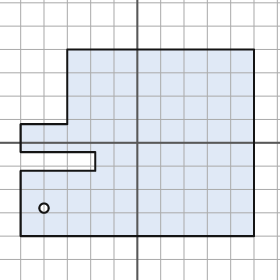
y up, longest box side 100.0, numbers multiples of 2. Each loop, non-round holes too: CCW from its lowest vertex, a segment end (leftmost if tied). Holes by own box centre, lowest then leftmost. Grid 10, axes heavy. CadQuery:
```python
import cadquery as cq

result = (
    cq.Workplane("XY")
    .moveTo(-50.0, -40.0)
    .lineTo(50.0, -40.0)
    .lineTo(50.0, 40.0)
    .lineTo(-30.0, 40.0)
    .lineTo(-30.0, 8.0)
    .lineTo(-50.0, 8.0)
    .lineTo(-50.0, -4.0)
    .lineTo(-18.0, -4.0)
    .lineTo(-18.0, -12.0)
    .lineTo(-50.0, -12.0)
    .close()
    .moveTo(-40.0, -28.0)
    .circle(2.0)
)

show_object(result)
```